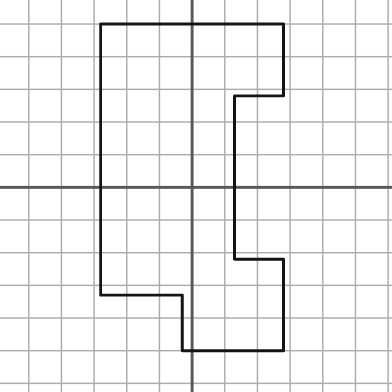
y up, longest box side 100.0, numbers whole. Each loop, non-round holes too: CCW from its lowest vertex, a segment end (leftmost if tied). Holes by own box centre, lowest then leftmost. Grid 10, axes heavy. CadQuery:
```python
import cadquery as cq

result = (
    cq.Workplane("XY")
    .moveTo(-3.0, -50.0)
    .lineTo(28.0, -50.0)
    .lineTo(28.0, -22.0)
    .lineTo(13.0, -22.0)
    .lineTo(13.0, 28.0)
    .lineTo(28.0, 28.0)
    .lineTo(28.0, 50.0)
    .lineTo(-28.0, 50.0)
    .lineTo(-28.0, -33.0)
    .lineTo(-3.0, -33.0)
    .close()
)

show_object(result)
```